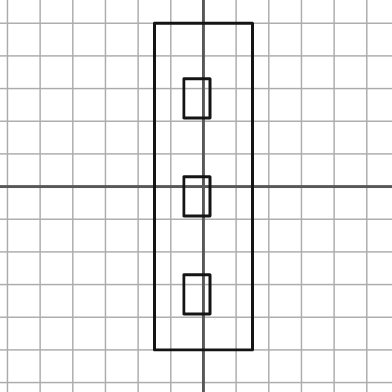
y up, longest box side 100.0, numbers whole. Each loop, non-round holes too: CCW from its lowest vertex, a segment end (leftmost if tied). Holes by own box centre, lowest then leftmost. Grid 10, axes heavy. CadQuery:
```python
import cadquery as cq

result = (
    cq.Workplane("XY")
    .moveTo(-15.0, -50.0)
    .lineTo(15.0, -50.0)
    .lineTo(15.0, 50.0)
    .lineTo(-15.0, 50.0)
    .close()
    .moveTo(-6.0, -39.0)
    .lineTo(2.0, -39.0)
    .lineTo(2.0, -27.0)
    .lineTo(-6.0, -27.0)
    .close()
    .moveTo(-6.0, -9.0)
    .lineTo(2.0, -9.0)
    .lineTo(2.0, 3.0)
    .lineTo(-6.0, 3.0)
    .close()
    .moveTo(-6.0, 21.0)
    .lineTo(2.0, 21.0)
    .lineTo(2.0, 33.0)
    .lineTo(-6.0, 33.0)
    .close()
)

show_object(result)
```